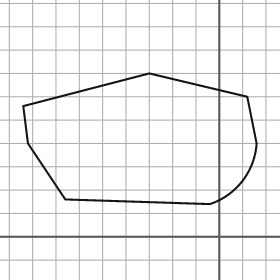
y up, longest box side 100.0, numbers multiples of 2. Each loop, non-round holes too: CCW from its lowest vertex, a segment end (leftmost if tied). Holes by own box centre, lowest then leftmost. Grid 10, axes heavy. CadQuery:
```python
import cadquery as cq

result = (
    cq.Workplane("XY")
    .moveTo(-4.0, 14.0)
    .threePointArc((10.0, 24.0), (16.0, 40.0))
    .lineTo(12.0, 60.0)
    .lineTo(-30.0, 70.0)
    .lineTo(-84.0, 56.0)
    .lineTo(-82.0, 40.0)
    .lineTo(-66.0, 16.0)
    .close()
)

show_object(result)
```